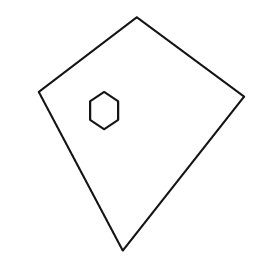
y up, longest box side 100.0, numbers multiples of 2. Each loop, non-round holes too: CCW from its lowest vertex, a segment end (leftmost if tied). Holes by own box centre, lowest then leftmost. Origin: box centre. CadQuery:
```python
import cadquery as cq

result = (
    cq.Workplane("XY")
    .moveTo(-8.0, -50.0)
    .lineTo(44.0, 16.0)
    .lineTo(-2.0, 50.0)
    .lineTo(-44.0, 18.0)
    .close()
    .moveTo(-16.0, 2.0)
    .lineTo(-10.0, 6.0)
    .lineTo(-10.0, 14.0)
    .lineTo(-16.0, 18.0)
    .lineTo(-22.0, 14.0)
    .lineTo(-22.0, 6.0)
    .close()
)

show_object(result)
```